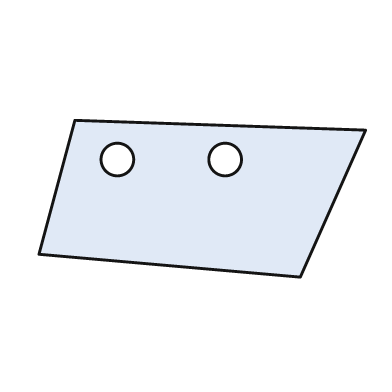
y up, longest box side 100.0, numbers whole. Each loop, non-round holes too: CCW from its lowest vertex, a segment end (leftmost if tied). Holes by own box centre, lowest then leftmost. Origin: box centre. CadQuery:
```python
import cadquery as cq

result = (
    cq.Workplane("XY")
    .moveTo(30.0, -24.0)
    .lineTo(50.0, 21.0)
    .lineTo(-39.0, 24.0)
    .lineTo(-50.0, -17.0)
    .close()
    .moveTo(-26.0, 12.0)
    .circle(5.0)
    .moveTo(7.0, 12.0)
    .circle(5.0)
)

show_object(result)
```